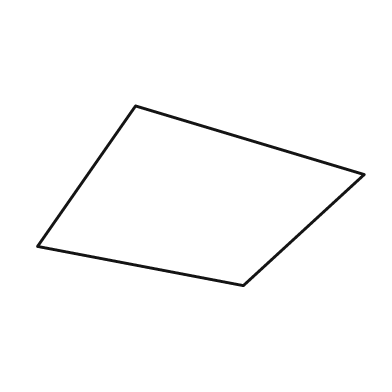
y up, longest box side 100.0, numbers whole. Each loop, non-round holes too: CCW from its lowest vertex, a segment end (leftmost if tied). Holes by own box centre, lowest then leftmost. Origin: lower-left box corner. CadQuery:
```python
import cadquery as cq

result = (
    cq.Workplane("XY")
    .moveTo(63.0, 0.0)
    .lineTo(100.0, 34.0)
    .lineTo(30.0, 55.0)
    .lineTo(0.0, 12.0)
    .close()
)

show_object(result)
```